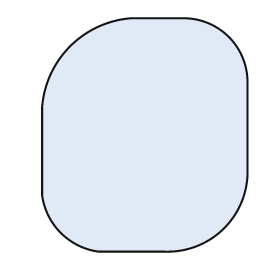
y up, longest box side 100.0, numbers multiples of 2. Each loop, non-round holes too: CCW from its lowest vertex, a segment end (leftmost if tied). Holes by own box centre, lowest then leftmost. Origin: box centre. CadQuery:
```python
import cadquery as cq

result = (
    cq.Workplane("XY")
    .moveTo(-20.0, -50.0)
    .lineTo(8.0, -50.0)
    .threePointArc((34.0, -40.0), (44.0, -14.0))
    .lineTo(44.0, 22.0)
    .threePointArc((36.0, 42.0), (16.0, 50.0))
    .lineTo(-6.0, 50.0)
    .threePointArc((-32.0, 38.0), (-44.0, 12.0))
    .lineTo(-44.0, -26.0)
    .threePointArc((-36.0, -42.0), (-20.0, -50.0))
    .close()
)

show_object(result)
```